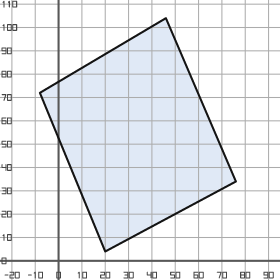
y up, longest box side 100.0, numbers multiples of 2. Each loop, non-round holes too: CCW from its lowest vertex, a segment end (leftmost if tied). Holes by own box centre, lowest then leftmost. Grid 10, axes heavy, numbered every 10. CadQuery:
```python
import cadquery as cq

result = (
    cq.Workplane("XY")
    .moveTo(20.0, 4.0)
    .lineTo(76.0, 34.0)
    .lineTo(46.0, 104.0)
    .lineTo(-8.0, 72.0)
    .close()
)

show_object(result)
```